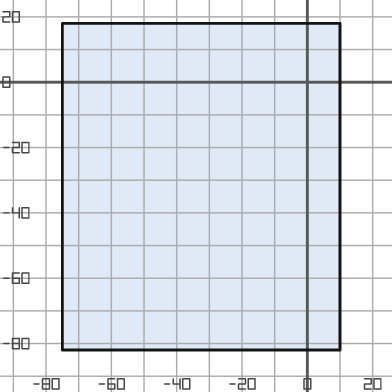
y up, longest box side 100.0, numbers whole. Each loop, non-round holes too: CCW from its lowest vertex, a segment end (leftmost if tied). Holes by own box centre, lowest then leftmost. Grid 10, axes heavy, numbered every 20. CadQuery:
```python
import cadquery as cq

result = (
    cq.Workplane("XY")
    .moveTo(-75.0, -82.0)
    .lineTo(10.0, -82.0)
    .lineTo(10.0, 18.0)
    .lineTo(-75.0, 18.0)
    .close()
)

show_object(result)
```